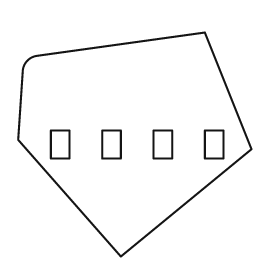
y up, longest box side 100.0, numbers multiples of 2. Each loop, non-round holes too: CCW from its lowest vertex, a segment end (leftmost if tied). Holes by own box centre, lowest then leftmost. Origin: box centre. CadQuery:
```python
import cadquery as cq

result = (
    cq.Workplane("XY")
    .moveTo(-6.0, -48.0)
    .lineTo(50.0, -2.0)
    .lineTo(30.0, 48.0)
    .lineTo(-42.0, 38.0)
    .threePointArc((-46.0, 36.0), (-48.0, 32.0))
    .lineTo(-50.0, 2.0)
    .close()
    .moveTo(-36.0, -6.0)
    .lineTo(-28.0, -6.0)
    .lineTo(-28.0, 6.0)
    .lineTo(-36.0, 6.0)
    .close()
    .moveTo(-14.0, -6.0)
    .lineTo(-6.0, -6.0)
    .lineTo(-6.0, 6.0)
    .lineTo(-14.0, 6.0)
    .close()
    .moveTo(8.0, -6.0)
    .lineTo(16.0, -6.0)
    .lineTo(16.0, 6.0)
    .lineTo(8.0, 6.0)
    .close()
    .moveTo(30.0, -6.0)
    .lineTo(38.0, -6.0)
    .lineTo(38.0, 6.0)
    .lineTo(30.0, 6.0)
    .close()
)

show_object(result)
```